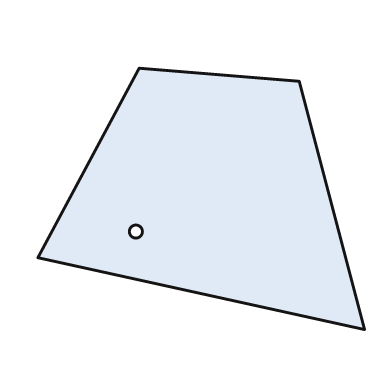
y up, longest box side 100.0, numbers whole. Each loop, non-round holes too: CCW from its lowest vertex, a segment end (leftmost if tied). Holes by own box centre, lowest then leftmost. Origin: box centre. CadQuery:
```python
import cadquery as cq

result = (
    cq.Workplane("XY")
    .moveTo(50.0, -40.0)
    .lineTo(30.0, 36.0)
    .lineTo(-19.0, 40.0)
    .lineTo(-50.0, -18.0)
    .close()
    .moveTo(-20.0, -10.0)
    .circle(2.0)
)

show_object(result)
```